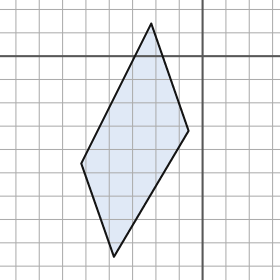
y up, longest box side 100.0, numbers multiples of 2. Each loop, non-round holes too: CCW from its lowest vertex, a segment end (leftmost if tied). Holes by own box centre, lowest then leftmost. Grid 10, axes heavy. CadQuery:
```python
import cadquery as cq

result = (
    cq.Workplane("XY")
    .moveTo(-38.0, -86.0)
    .lineTo(-6.0, -32.0)
    .lineTo(-22.0, 14.0)
    .lineTo(-52.0, -46.0)
    .close()
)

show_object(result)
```